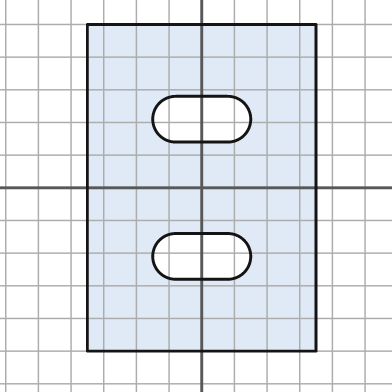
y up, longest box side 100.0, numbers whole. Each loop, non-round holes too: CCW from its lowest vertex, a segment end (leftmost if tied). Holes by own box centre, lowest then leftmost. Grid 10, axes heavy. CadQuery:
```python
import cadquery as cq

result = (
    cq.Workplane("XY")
    .moveTo(-35.0, -50.0)
    .lineTo(35.0, -50.0)
    .lineTo(35.0, 50.0)
    .lineTo(-35.0, 50.0)
    .close()
    .moveTo(-8.0, -28.0)
    .lineTo(8.0, -28.0)
    .threePointArc((15.0, -21.0), (8.0, -14.0))
    .lineTo(-8.0, -14.0)
    .threePointArc((-15.0, -21.0), (-8.0, -28.0))
    .close()
    .moveTo(-8.0, 14.0)
    .lineTo(8.0, 14.0)
    .threePointArc((15.0, 21.0), (8.0, 28.0))
    .lineTo(-8.0, 28.0)
    .threePointArc((-15.0, 21.0), (-8.0, 14.0))
    .close()
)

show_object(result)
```